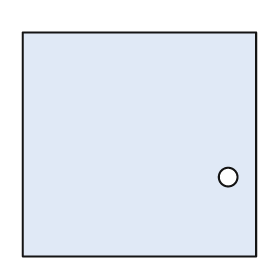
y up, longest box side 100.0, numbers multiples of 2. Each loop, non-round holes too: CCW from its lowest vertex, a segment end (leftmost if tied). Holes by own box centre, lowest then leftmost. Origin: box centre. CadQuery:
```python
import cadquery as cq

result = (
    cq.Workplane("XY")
    .moveTo(-50.0, -48.0)
    .lineTo(50.0, -48.0)
    .lineTo(50.0, 48.0)
    .lineTo(-50.0, 48.0)
    .close()
    .moveTo(38.0, -14.0)
    .circle(4.0)
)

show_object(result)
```